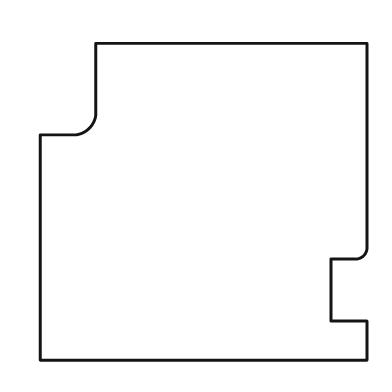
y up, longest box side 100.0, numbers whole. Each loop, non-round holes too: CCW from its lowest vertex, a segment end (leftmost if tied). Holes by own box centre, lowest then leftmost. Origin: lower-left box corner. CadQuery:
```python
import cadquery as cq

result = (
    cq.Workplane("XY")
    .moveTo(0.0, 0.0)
    .lineTo(100.0, 0.0)
    .lineTo(100.0, 12.0)
    .lineTo(89.0, 12.0)
    .lineTo(89.0, 31.0)
    .lineTo(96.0, 31.0)
    .threePointArc((99.0, 32.0), (100.0, 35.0))
    .lineTo(100.0, 97.0)
    .lineTo(17.0, 97.0)
    .lineTo(17.0, 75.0)
    .threePointArc((15.0, 71.0), (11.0, 69.0))
    .lineTo(0.0, 69.0)
    .close()
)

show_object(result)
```